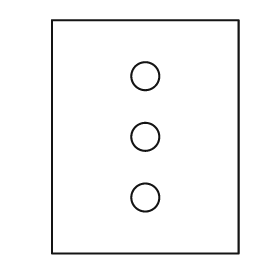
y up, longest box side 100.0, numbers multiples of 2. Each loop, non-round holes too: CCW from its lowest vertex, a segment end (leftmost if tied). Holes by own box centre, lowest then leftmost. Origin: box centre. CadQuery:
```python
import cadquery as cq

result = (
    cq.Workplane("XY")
    .moveTo(-40.0, -50.0)
    .lineTo(40.0, -50.0)
    .lineTo(40.0, 50.0)
    .lineTo(-40.0, 50.0)
    .close()
    .moveTo(0.0, -26.0)
    .circle(6.0)
    .moveTo(0.0, 0.0)
    .circle(6.0)
    .moveTo(0.0, 26.0)
    .circle(6.0)
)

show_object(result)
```